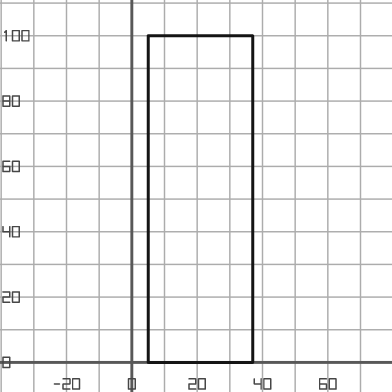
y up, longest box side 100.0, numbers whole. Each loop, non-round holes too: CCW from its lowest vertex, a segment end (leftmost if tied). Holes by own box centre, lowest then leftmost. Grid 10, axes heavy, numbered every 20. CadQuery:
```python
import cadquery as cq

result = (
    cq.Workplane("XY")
    .moveTo(5.0, 0.0)
    .lineTo(37.0, 0.0)
    .lineTo(37.0, 100.0)
    .lineTo(5.0, 100.0)
    .close()
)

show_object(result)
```